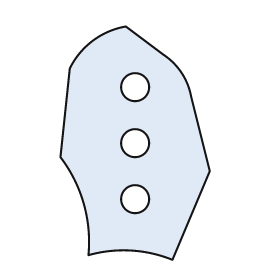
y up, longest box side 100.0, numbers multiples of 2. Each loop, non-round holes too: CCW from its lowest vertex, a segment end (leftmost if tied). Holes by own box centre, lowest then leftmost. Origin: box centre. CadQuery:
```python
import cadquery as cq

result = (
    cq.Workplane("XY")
    .moveTo(16.0, -50.0)
    .lineTo(32.0, -12.0)
    .lineTo(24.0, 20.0)
    .threePointArc((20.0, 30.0), (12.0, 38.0))
    .lineTo(-4.0, 50.0)
    .threePointArc((-18.0, 44.0), (-28.0, 32.0))
    .lineTo(-32.0, -6.0)
    .threePointArc((-22.0, -26.0), (-20.0, -48.0))
    .threePointArc((-2.0, -46.0), (16.0, -50.0))
    .close()
    .moveTo(0.0, -24.0)
    .circle(6.0)
    .moveTo(0.0, 0.0)
    .circle(6.0)
    .moveTo(0.0, 24.0)
    .circle(6.0)
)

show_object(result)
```